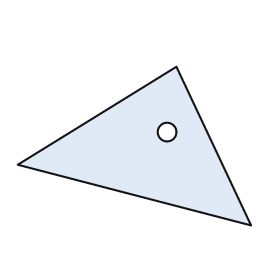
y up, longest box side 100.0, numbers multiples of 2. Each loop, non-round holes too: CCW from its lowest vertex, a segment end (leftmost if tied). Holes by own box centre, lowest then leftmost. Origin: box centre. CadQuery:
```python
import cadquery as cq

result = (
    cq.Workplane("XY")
    .moveTo(50.0, -34.0)
    .lineTo(18.0, 34.0)
    .lineTo(-50.0, -8.0)
    .close()
    .moveTo(14.0, 6.0)
    .circle(4.0)
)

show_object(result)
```